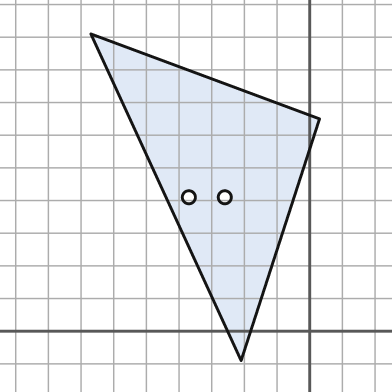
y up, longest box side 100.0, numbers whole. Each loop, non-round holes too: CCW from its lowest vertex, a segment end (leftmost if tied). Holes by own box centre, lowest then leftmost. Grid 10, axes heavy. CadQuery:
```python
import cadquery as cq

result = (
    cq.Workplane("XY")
    .moveTo(-21.0, -9.0)
    .lineTo(3.0, 65.0)
    .lineTo(-67.0, 91.0)
    .close()
    .moveTo(-37.0, 41.0)
    .circle(2.0)
    .moveTo(-26.0, 41.0)
    .circle(2.0)
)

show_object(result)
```